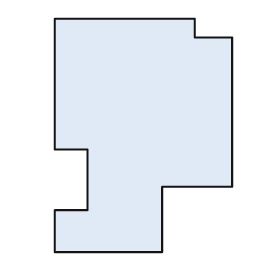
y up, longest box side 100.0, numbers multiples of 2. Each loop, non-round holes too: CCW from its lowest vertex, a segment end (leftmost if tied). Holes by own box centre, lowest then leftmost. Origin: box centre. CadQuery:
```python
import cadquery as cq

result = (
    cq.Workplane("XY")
    .moveTo(-38.0, -50.0)
    .lineTo(8.0, -50.0)
    .lineTo(8.0, -22.0)
    .lineTo(38.0, -22.0)
    .lineTo(38.0, 42.0)
    .lineTo(22.0, 42.0)
    .lineTo(22.0, 50.0)
    .lineTo(-38.0, 50.0)
    .lineTo(-38.0, -6.0)
    .lineTo(-24.0, -6.0)
    .lineTo(-24.0, -32.0)
    .lineTo(-38.0, -32.0)
    .close()
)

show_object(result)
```